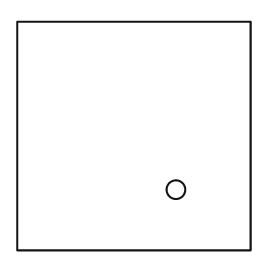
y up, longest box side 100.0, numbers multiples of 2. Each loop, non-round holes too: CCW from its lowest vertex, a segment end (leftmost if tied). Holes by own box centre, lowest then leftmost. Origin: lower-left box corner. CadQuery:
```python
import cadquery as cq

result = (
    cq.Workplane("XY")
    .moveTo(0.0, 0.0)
    .lineTo(100.0, 0.0)
    .lineTo(100.0, 98.0)
    .lineTo(0.0, 98.0)
    .close()
    .moveTo(68.0, 26.0)
    .circle(4.0)
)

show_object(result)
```